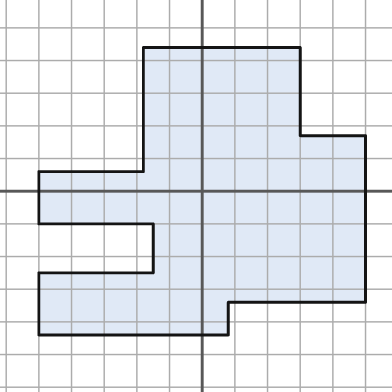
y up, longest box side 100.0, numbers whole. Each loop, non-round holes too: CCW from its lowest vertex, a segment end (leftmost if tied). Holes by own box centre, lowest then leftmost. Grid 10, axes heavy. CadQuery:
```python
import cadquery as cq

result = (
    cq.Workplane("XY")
    .moveTo(-50.0, -44.0)
    .lineTo(8.0, -44.0)
    .lineTo(8.0, -34.0)
    .lineTo(50.0, -34.0)
    .lineTo(50.0, 17.0)
    .lineTo(30.0, 17.0)
    .lineTo(30.0, 44.0)
    .lineTo(-18.0, 44.0)
    .lineTo(-18.0, 6.0)
    .lineTo(-50.0, 6.0)
    .lineTo(-50.0, -10.0)
    .lineTo(-15.0, -10.0)
    .lineTo(-15.0, -25.0)
    .lineTo(-50.0, -25.0)
    .close()
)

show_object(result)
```